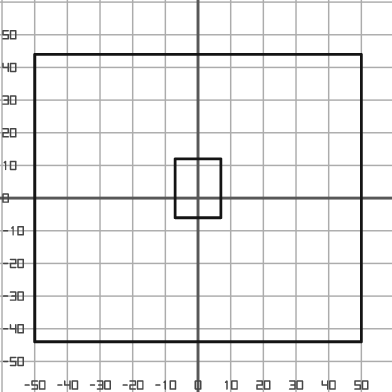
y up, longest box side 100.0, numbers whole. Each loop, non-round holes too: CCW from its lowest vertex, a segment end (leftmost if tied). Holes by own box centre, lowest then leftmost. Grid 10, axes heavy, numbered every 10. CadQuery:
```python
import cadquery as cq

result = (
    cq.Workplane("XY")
    .moveTo(-50.0, -44.0)
    .lineTo(50.0, -44.0)
    .lineTo(50.0, 44.0)
    .lineTo(-50.0, 44.0)
    .close()
    .moveTo(-7.0, -6.0)
    .lineTo(7.0, -6.0)
    .lineTo(7.0, 12.0)
    .lineTo(-7.0, 12.0)
    .close()
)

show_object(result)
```